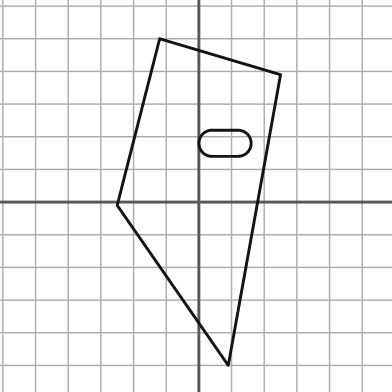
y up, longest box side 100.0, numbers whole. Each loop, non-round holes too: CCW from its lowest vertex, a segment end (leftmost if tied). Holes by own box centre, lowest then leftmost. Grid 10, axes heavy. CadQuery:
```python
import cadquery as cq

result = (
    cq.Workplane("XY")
    .moveTo(9.0, -50.0)
    .lineTo(25.0, 39.0)
    .lineTo(-12.0, 50.0)
    .lineTo(-25.0, -1.0)
    .close()
    .moveTo(4.0, 14.0)
    .lineTo(12.0, 14.0)
    .threePointArc((16.0, 18.0), (12.0, 22.0))
    .lineTo(4.0, 22.0)
    .threePointArc((0.0, 18.0), (4.0, 14.0))
    .close()
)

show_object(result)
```